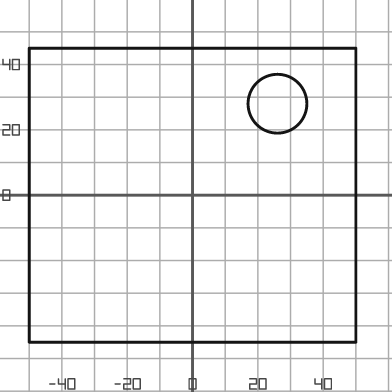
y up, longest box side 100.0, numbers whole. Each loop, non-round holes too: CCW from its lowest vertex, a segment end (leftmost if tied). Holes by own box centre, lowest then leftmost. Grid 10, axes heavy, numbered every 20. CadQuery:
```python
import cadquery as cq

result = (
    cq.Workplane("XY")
    .moveTo(-50.0, -45.0)
    .lineTo(50.0, -45.0)
    .lineTo(50.0, 45.0)
    .lineTo(-50.0, 45.0)
    .close()
    .moveTo(26.0, 28.0)
    .circle(9.0)
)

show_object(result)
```